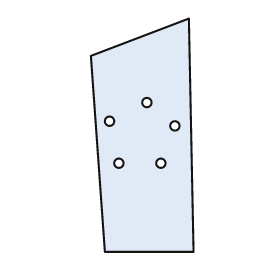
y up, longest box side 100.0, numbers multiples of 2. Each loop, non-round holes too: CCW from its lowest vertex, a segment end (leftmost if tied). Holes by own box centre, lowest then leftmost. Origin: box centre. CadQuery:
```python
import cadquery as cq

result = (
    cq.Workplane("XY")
    .moveTo(-16.0, -50.0)
    .lineTo(22.0, -50.0)
    .lineTo(20.0, 50.0)
    .lineTo(-22.0, 34.0)
    .close()
    .moveTo(-10.0, -12.0)
    .circle(2.0)
    .moveTo(8.0, -12.0)
    .circle(2.0)
    .moveTo(14.0, 4.0)
    .circle(2.0)
    .moveTo(-14.0, 6.0)
    .circle(2.0)
    .moveTo(2.0, 14.0)
    .circle(2.0)
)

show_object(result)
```